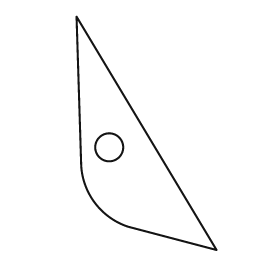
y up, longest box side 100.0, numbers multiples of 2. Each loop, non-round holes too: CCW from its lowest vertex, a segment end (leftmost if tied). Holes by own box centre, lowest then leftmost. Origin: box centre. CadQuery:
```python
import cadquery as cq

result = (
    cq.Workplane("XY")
    .moveTo(30.0, -50.0)
    .lineTo(-30.0, 50.0)
    .lineTo(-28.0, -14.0)
    .threePointArc((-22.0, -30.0), (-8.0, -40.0))
    .close()
    .moveTo(-16.0, -6.0)
    .circle(6.0)
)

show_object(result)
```